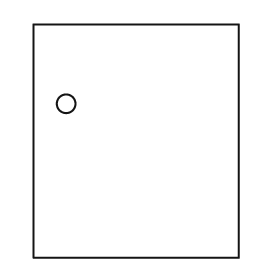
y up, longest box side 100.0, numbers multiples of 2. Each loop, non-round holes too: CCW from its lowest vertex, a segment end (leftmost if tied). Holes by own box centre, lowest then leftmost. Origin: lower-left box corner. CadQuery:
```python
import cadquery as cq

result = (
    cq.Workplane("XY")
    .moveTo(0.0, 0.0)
    .lineTo(88.0, 0.0)
    .lineTo(88.0, 100.0)
    .lineTo(0.0, 100.0)
    .close()
    .moveTo(14.0, 66.0)
    .circle(4.0)
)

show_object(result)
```